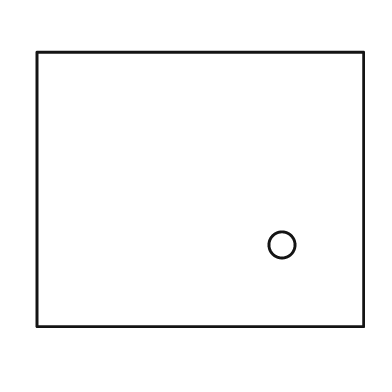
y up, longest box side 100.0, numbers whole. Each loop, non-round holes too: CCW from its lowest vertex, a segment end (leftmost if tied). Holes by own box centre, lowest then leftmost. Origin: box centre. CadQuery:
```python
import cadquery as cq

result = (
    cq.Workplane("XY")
    .moveTo(-50.0, -42.0)
    .lineTo(50.0, -42.0)
    .lineTo(50.0, 42.0)
    .lineTo(-50.0, 42.0)
    .close()
    .moveTo(25.0, -17.0)
    .circle(4.0)
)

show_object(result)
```